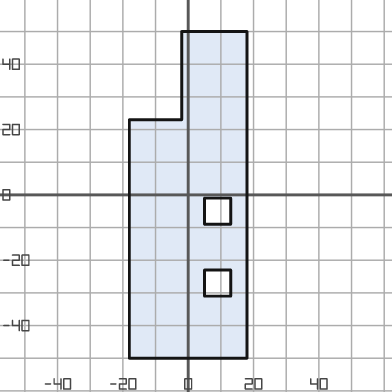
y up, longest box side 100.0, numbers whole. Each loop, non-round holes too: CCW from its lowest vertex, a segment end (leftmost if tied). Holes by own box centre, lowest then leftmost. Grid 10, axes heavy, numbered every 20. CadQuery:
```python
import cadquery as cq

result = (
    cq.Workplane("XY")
    .moveTo(-18.0, -50.0)
    .lineTo(18.0, -50.0)
    .lineTo(18.0, 50.0)
    .lineTo(-2.0, 50.0)
    .lineTo(-2.0, 23.0)
    .lineTo(-18.0, 23.0)
    .close()
    .moveTo(5.0, -31.0)
    .lineTo(13.0, -31.0)
    .lineTo(13.0, -23.0)
    .lineTo(5.0, -23.0)
    .close()
    .moveTo(5.0, -9.0)
    .lineTo(13.0, -9.0)
    .lineTo(13.0, -1.0)
    .lineTo(5.0, -1.0)
    .close()
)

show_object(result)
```